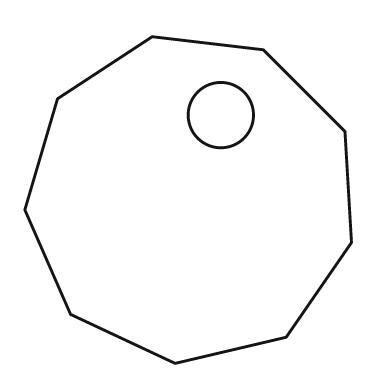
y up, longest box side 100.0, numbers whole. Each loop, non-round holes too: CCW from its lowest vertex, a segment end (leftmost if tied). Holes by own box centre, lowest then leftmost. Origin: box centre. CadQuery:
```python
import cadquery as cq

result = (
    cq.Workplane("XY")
    .moveTo(-4.0, -50.0)
    .lineTo(30.0, -42.0)
    .lineTo(50.0, -13.0)
    .lineTo(48.0, 21.0)
    .lineTo(23.0, 46.0)
    .lineTo(-11.0, 50.0)
    .lineTo(-40.0, 31.0)
    .lineTo(-50.0, -3.0)
    .lineTo(-36.0, -35.0)
    .close()
    .moveTo(10.0, 26.0)
    .circle(10.0)
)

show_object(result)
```